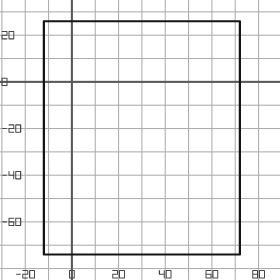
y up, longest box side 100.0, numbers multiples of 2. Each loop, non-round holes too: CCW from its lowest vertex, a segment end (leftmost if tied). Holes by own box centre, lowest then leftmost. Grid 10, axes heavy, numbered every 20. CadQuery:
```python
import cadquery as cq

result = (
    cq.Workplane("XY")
    .moveTo(-12.0, -74.0)
    .lineTo(72.0, -74.0)
    .lineTo(72.0, 26.0)
    .lineTo(-12.0, 26.0)
    .close()
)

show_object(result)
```